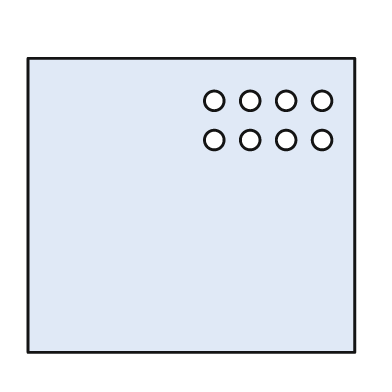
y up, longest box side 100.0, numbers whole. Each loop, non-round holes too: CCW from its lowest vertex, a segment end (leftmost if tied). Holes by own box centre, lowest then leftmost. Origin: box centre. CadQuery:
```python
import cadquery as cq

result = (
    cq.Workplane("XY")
    .moveTo(-50.0, -45.0)
    .lineTo(50.0, -45.0)
    .lineTo(50.0, 45.0)
    .lineTo(-50.0, 45.0)
    .close()
    .moveTo(7.0, 20.0)
    .circle(3.0)
    .moveTo(18.0, 20.0)
    .circle(3.0)
    .moveTo(29.0, 20.0)
    .circle(3.0)
    .moveTo(40.0, 20.0)
    .circle(3.0)
    .moveTo(7.0, 32.0)
    .circle(3.0)
    .moveTo(18.0, 32.0)
    .circle(3.0)
    .moveTo(29.0, 32.0)
    .circle(3.0)
    .moveTo(40.0, 32.0)
    .circle(3.0)
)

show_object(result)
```